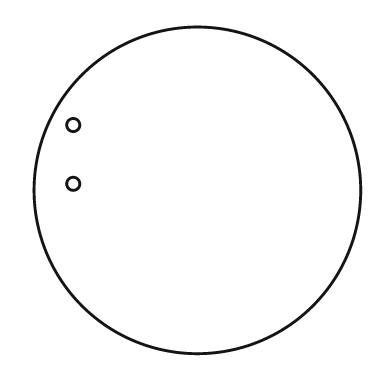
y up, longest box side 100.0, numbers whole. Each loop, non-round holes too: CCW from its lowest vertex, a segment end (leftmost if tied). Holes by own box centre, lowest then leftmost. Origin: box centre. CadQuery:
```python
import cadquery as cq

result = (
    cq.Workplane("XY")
    .moveTo(0.0, 0.0)
    .circle(50.0)
    .moveTo(-38.0, 2.0)
    .circle(2.0)
    .moveTo(-38.0, 20.0)
    .circle(2.0)
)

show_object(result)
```